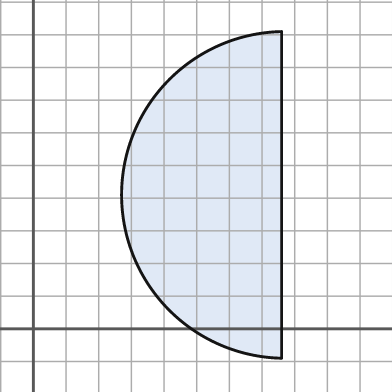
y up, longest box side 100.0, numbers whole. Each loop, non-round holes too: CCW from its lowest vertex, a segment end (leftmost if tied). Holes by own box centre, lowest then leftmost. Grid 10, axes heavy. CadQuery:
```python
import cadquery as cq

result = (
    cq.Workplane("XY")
    .moveTo(76.0, -9.0)
    .lineTo(76.0, 91.0)
    .threePointArc((27.0, 41.0), (76.0, -9.0))
    .close()
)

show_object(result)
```